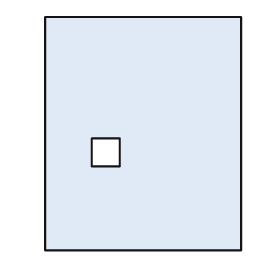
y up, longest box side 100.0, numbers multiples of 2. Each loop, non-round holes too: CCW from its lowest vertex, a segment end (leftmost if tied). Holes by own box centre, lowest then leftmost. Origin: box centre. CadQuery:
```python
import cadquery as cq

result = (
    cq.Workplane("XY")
    .moveTo(-42.0, -50.0)
    .lineTo(42.0, -50.0)
    .lineTo(42.0, 50.0)
    .lineTo(-42.0, 50.0)
    .close()
    .moveTo(-22.0, -14.0)
    .lineTo(-10.0, -14.0)
    .lineTo(-10.0, -2.0)
    .lineTo(-22.0, -2.0)
    .close()
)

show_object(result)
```